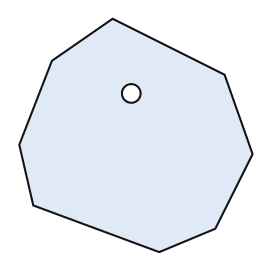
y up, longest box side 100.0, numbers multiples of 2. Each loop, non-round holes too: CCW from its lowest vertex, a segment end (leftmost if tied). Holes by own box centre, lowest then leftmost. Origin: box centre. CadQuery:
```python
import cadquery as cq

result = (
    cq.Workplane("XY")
    .moveTo(10.0, -50.0)
    .lineTo(34.0, -40.0)
    .lineTo(50.0, -8.0)
    .lineTo(38.0, 26.0)
    .lineTo(-10.0, 50.0)
    .lineTo(-36.0, 32.0)
    .lineTo(-50.0, -4.0)
    .lineTo(-44.0, -30.0)
    .close()
    .moveTo(-2.0, 18.0)
    .circle(4.0)
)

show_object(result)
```